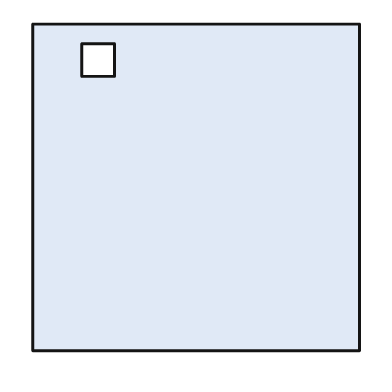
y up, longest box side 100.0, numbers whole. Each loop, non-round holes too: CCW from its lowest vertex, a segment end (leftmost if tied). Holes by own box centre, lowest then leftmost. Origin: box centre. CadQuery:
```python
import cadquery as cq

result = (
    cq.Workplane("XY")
    .moveTo(-50.0, -50.0)
    .lineTo(50.0, -50.0)
    .lineTo(50.0, 50.0)
    .lineTo(-50.0, 50.0)
    .close()
    .moveTo(-35.0, 34.0)
    .lineTo(-25.0, 34.0)
    .lineTo(-25.0, 44.0)
    .lineTo(-35.0, 44.0)
    .close()
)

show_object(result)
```